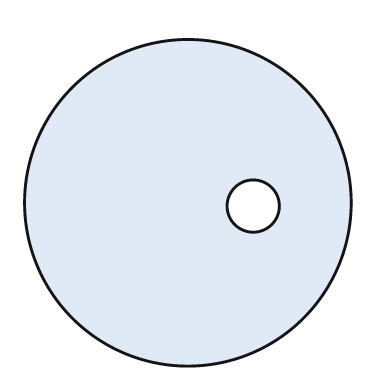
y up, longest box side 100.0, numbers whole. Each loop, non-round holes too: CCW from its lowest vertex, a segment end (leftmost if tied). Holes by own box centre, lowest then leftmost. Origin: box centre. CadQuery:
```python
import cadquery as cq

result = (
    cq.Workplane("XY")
    .moveTo(0.0, 0.0)
    .circle(50.0)
    .moveTo(20.0, -1.0)
    .circle(8.0)
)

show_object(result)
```